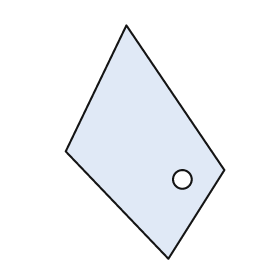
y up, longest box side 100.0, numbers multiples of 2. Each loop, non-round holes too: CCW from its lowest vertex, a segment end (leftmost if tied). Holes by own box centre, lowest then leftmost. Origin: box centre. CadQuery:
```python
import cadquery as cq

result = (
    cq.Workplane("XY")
    .moveTo(10.0, -50.0)
    .lineTo(34.0, -12.0)
    .lineTo(-8.0, 50.0)
    .lineTo(-34.0, -4.0)
    .close()
    .moveTo(16.0, -16.0)
    .circle(4.0)
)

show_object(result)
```